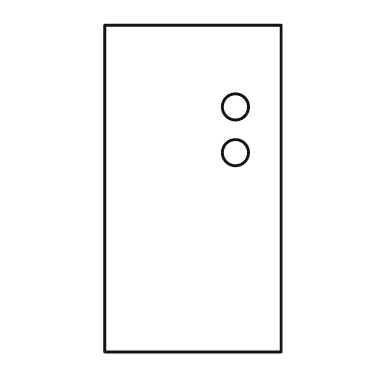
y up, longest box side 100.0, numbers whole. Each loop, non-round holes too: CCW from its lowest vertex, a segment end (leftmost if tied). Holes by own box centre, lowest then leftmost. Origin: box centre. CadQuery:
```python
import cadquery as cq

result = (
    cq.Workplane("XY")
    .moveTo(-27.0, -50.0)
    .lineTo(27.0, -50.0)
    .lineTo(27.0, 50.0)
    .lineTo(-27.0, 50.0)
    .close()
    .moveTo(13.0, 11.0)
    .circle(4.0)
    .moveTo(13.0, 25.0)
    .circle(4.0)
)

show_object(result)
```